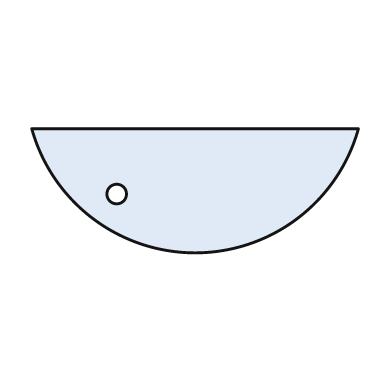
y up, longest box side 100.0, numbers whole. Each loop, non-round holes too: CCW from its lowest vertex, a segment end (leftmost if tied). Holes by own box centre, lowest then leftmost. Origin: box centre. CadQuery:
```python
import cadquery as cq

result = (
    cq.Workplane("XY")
    .moveTo(-50.0, 19.0)
    .threePointArc((0.0, -19.0), (50.0, 19.0))
    .close()
    .moveTo(-24.0, -1.0)
    .circle(3.0)
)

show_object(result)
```